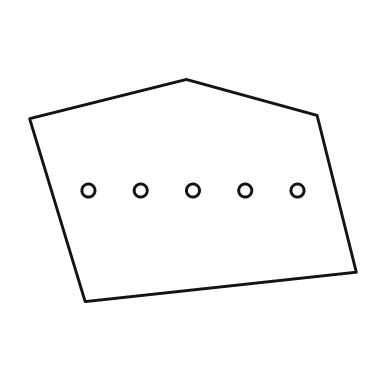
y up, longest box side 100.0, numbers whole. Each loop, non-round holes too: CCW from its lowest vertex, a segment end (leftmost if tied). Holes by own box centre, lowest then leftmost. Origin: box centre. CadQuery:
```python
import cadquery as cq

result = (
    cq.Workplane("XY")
    .moveTo(-33.0, -34.0)
    .lineTo(50.0, -25.0)
    .lineTo(38.0, 23.0)
    .lineTo(-2.0, 34.0)
    .lineTo(-50.0, 22.0)
    .close()
    .moveTo(-32.0, 0.0)
    .circle(2.0)
    .moveTo(-16.0, 0.0)
    .circle(2.0)
    .moveTo(0.0, 0.0)
    .circle(2.0)
    .moveTo(16.0, 0.0)
    .circle(2.0)
    .moveTo(32.0, 0.0)
    .circle(2.0)
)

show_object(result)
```